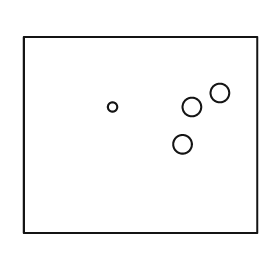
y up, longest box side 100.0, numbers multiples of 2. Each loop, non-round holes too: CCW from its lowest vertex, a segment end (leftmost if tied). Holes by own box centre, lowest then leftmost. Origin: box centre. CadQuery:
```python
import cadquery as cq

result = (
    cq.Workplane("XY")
    .moveTo(-50.0, -42.0)
    .lineTo(50.0, -42.0)
    .lineTo(50.0, 42.0)
    .lineTo(-50.0, 42.0)
    .close()
    .moveTo(18.0, -4.0)
    .circle(4.0)
    .moveTo(-12.0, 12.0)
    .circle(2.0)
    .moveTo(22.0, 12.0)
    .circle(4.0)
    .moveTo(34.0, 18.0)
    .circle(4.0)
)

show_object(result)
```